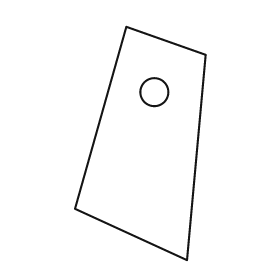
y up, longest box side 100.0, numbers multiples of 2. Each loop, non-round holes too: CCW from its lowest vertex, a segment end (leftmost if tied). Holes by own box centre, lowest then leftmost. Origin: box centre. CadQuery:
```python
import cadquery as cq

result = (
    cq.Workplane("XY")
    .moveTo(20.0, -50.0)
    .lineTo(28.0, 38.0)
    .lineTo(-6.0, 50.0)
    .lineTo(-28.0, -28.0)
    .close()
    .moveTo(6.0, 22.0)
    .circle(6.0)
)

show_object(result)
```